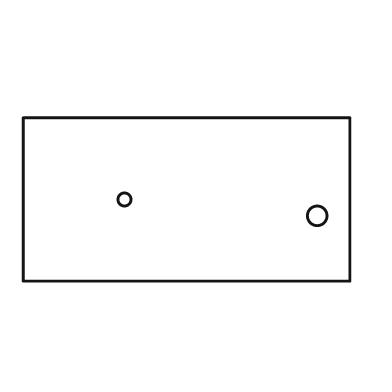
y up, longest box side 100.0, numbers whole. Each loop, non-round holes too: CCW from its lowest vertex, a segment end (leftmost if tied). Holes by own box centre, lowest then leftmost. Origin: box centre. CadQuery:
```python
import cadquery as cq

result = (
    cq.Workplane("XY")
    .moveTo(-50.0, -25.0)
    .lineTo(50.0, -25.0)
    .lineTo(50.0, 25.0)
    .lineTo(-50.0, 25.0)
    .close()
    .moveTo(40.0, -5.0)
    .circle(3.0)
    .moveTo(-19.0, 0.0)
    .circle(2.0)
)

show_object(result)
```